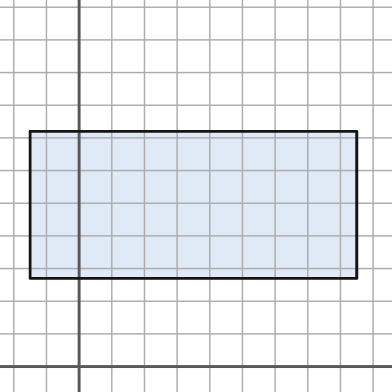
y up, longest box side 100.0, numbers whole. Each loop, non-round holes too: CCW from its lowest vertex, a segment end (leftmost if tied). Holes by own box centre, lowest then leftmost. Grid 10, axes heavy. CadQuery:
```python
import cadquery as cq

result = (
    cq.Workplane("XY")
    .moveTo(-15.0, 27.0)
    .lineTo(85.0, 27.0)
    .lineTo(85.0, 72.0)
    .lineTo(-15.0, 72.0)
    .close()
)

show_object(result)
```